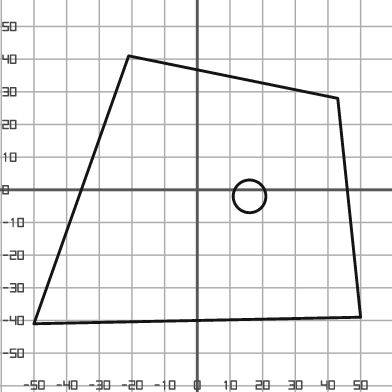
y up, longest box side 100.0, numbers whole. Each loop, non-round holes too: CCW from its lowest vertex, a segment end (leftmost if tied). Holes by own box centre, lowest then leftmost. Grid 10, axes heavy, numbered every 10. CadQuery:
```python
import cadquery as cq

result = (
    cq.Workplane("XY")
    .moveTo(-50.0, -41.0)
    .lineTo(50.0, -39.0)
    .lineTo(43.0, 28.0)
    .lineTo(-21.0, 41.0)
    .close()
    .moveTo(16.0, -2.0)
    .circle(5.0)
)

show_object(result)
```